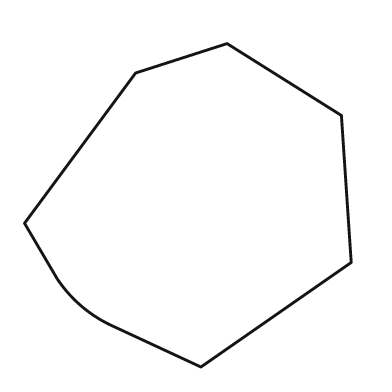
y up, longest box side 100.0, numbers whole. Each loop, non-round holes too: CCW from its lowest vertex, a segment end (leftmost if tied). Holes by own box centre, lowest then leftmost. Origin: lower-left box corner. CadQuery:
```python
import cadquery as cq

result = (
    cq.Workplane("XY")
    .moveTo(54.0, 0.0)
    .lineTo(100.0, 32.0)
    .lineTo(97.0, 77.0)
    .lineTo(62.0, 99.0)
    .lineTo(34.0, 90.0)
    .lineTo(0.0, 44.0)
    .lineTo(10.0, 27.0)
    .threePointArc((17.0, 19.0), (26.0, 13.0))
    .close()
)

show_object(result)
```